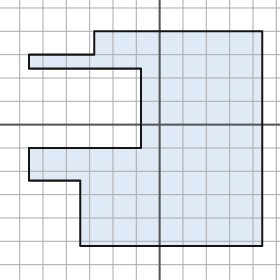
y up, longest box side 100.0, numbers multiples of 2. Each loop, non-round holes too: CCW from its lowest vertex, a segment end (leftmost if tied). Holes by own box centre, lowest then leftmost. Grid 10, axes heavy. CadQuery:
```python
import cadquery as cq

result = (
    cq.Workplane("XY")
    .moveTo(-34.0, -52.0)
    .lineTo(44.0, -52.0)
    .lineTo(44.0, 40.0)
    .lineTo(-28.0, 40.0)
    .lineTo(-28.0, 30.0)
    .lineTo(-56.0, 30.0)
    .lineTo(-56.0, 24.0)
    .lineTo(-8.0, 24.0)
    .lineTo(-8.0, -10.0)
    .lineTo(-56.0, -10.0)
    .lineTo(-56.0, -24.0)
    .lineTo(-34.0, -24.0)
    .close()
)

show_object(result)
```